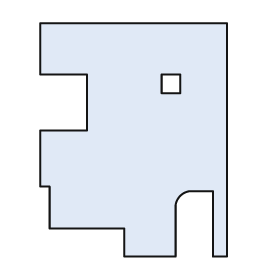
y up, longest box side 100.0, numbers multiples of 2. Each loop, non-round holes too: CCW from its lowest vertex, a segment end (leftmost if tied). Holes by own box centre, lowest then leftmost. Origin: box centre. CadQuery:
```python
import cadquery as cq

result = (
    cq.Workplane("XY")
    .moveTo(-4.0, -50.0)
    .lineTo(18.0, -50.0)
    .lineTo(18.0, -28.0)
    .threePointArc((20.0, -24.0), (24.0, -22.0))
    .lineTo(34.0, -22.0)
    .lineTo(34.0, -50.0)
    .lineTo(40.0, -50.0)
    .lineTo(40.0, 50.0)
    .lineTo(-40.0, 50.0)
    .lineTo(-40.0, 28.0)
    .lineTo(-20.0, 28.0)
    .lineTo(-20.0, 4.0)
    .lineTo(-40.0, 4.0)
    .lineTo(-40.0, -20.0)
    .lineTo(-36.0, -20.0)
    .lineTo(-36.0, -38.0)
    .lineTo(-4.0, -38.0)
    .close()
    .moveTo(12.0, 20.0)
    .lineTo(20.0, 20.0)
    .lineTo(20.0, 28.0)
    .lineTo(12.0, 28.0)
    .close()
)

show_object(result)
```